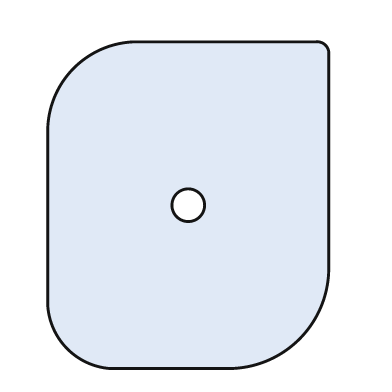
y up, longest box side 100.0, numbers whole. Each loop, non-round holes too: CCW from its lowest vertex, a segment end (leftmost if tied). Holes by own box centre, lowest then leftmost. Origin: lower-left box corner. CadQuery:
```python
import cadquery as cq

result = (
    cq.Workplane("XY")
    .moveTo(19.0, 0.0)
    .lineTo(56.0, 0.0)
    .threePointArc((77.0, 9.0), (86.0, 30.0))
    .lineTo(86.0, 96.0)
    .threePointArc((85.0, 99.0), (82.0, 100.0))
    .lineTo(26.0, 100.0)
    .threePointArc((8.0, 92.0), (0.0, 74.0))
    .lineTo(0.0, 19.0)
    .threePointArc((6.0, 6.0), (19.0, 0.0))
    .close()
    .moveTo(43.0, 50.0)
    .circle(5.0)
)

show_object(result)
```